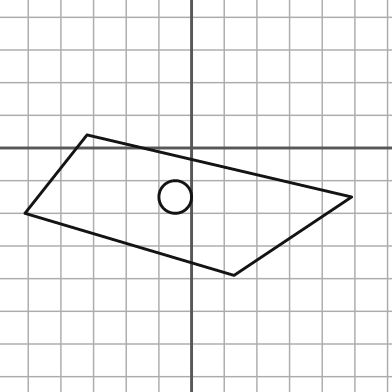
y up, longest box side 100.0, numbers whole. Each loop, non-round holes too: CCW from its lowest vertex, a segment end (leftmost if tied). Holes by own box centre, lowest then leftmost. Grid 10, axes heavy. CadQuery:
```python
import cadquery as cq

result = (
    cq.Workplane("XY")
    .moveTo(13.0, -39.0)
    .lineTo(49.0, -15.0)
    .lineTo(-32.0, 4.0)
    .lineTo(-51.0, -20.0)
    .close()
    .moveTo(-5.0, -15.0)
    .circle(5.0)
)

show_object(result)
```